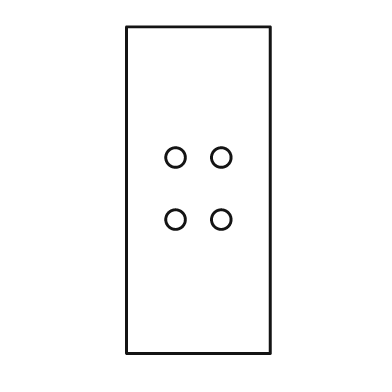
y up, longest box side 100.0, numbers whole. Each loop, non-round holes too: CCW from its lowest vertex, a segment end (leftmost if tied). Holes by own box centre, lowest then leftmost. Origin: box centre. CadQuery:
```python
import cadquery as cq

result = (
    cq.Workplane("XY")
    .moveTo(-22.0, -50.0)
    .lineTo(22.0, -50.0)
    .lineTo(22.0, 50.0)
    .lineTo(-22.0, 50.0)
    .close()
    .moveTo(-7.0, -9.0)
    .circle(3.0)
    .moveTo(7.0, -9.0)
    .circle(3.0)
    .moveTo(-7.0, 10.0)
    .circle(3.0)
    .moveTo(7.0, 10.0)
    .circle(3.0)
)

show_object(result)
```